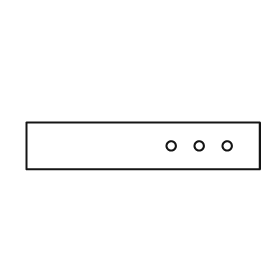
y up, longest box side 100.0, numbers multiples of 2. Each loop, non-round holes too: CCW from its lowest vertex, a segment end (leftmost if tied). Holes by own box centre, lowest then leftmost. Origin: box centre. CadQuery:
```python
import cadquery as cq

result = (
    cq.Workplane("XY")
    .moveTo(-50.0, -10.0)
    .lineTo(50.0, -10.0)
    .lineTo(50.0, 10.0)
    .lineTo(-50.0, 10.0)
    .close()
    .moveTo(12.0, 0.0)
    .circle(2.0)
    .moveTo(24.0, 0.0)
    .circle(2.0)
    .moveTo(36.0, 0.0)
    .circle(2.0)
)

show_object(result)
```